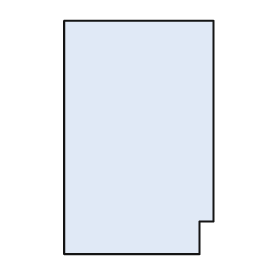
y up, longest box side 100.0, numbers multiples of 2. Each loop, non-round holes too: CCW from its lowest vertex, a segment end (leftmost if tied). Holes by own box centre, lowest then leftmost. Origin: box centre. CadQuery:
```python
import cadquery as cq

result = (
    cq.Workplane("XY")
    .moveTo(-32.0, -50.0)
    .lineTo(26.0, -50.0)
    .lineTo(26.0, -36.0)
    .lineTo(32.0, -36.0)
    .lineTo(32.0, 50.0)
    .lineTo(-32.0, 50.0)
    .close()
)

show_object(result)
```